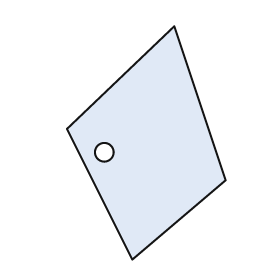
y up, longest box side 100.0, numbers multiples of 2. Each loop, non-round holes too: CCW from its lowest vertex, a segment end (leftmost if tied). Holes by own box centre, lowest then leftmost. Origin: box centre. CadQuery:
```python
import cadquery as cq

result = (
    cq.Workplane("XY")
    .moveTo(-6.0, -50.0)
    .lineTo(34.0, -16.0)
    .lineTo(12.0, 50.0)
    .lineTo(-34.0, 6.0)
    .close()
    .moveTo(-18.0, -4.0)
    .circle(4.0)
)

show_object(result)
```